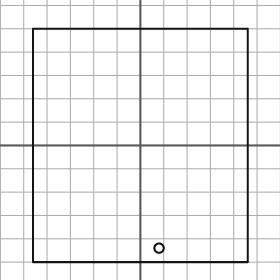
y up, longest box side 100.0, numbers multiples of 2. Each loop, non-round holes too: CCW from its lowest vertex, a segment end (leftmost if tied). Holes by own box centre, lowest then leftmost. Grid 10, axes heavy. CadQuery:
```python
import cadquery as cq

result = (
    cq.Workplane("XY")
    .moveTo(-46.0, -50.0)
    .lineTo(46.0, -50.0)
    .lineTo(46.0, 50.0)
    .lineTo(-46.0, 50.0)
    .close()
    .moveTo(8.0, -44.0)
    .circle(2.0)
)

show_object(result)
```